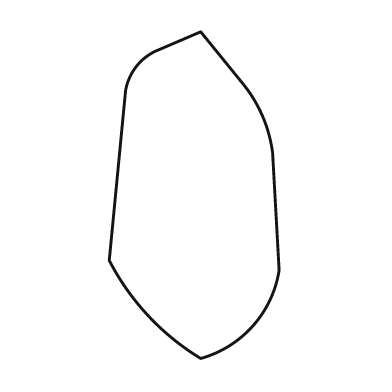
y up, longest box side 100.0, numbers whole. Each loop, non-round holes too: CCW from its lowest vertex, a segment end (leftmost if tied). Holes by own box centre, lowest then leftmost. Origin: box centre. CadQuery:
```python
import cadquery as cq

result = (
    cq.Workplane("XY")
    .moveTo(2.0, -50.0)
    .threePointArc((18.0, -40.0), (26.0, -23.0))
    .lineTo(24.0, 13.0)
    .threePointArc((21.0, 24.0), (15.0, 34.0))
    .lineTo(2.0, 50.0)
    .lineTo(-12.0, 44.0)
    .threePointArc((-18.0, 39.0), (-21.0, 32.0))
    .lineTo(-26.0, -20.0)
    .threePointArc((-14.0, -37.0), (2.0, -50.0))
    .close()
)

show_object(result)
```